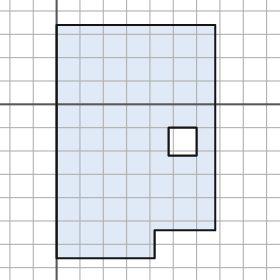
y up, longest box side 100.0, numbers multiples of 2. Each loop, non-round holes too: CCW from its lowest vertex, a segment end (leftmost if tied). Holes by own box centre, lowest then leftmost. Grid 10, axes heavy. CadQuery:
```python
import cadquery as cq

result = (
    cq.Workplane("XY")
    .moveTo(0.0, -66.0)
    .lineTo(42.0, -66.0)
    .lineTo(42.0, -54.0)
    .lineTo(68.0, -54.0)
    .lineTo(68.0, 34.0)
    .lineTo(0.0, 34.0)
    .close()
    .moveTo(48.0, -22.0)
    .lineTo(60.0, -22.0)
    .lineTo(60.0, -10.0)
    .lineTo(48.0, -10.0)
    .close()
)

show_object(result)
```